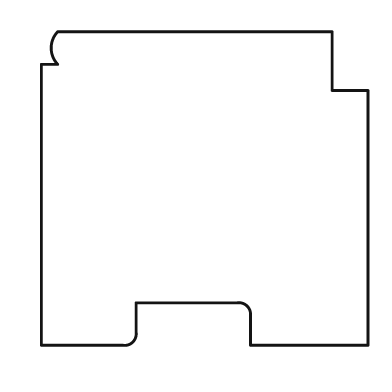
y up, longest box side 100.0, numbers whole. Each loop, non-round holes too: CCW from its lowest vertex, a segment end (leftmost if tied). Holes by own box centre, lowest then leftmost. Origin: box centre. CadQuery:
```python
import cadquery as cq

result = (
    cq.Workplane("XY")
    .moveTo(-50.0, -48.0)
    .lineTo(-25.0, -48.0)
    .threePointArc((-22.0, -47.0), (-21.0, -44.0))
    .lineTo(-21.0, -35.0)
    .lineTo(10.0, -35.0)
    .threePointArc((13.0, -36.0), (14.0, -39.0))
    .lineTo(14.0, -48.0)
    .lineTo(50.0, -48.0)
    .lineTo(50.0, 30.0)
    .lineTo(39.0, 30.0)
    .lineTo(39.0, 48.0)
    .lineTo(-45.0, 48.0)
    .threePointArc((-47.0, 43.0), (-45.0, 38.0))
    .lineTo(-50.0, 38.0)
    .close()
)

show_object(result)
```